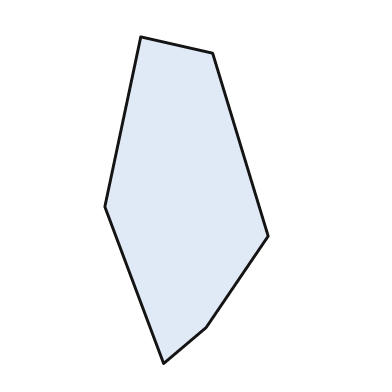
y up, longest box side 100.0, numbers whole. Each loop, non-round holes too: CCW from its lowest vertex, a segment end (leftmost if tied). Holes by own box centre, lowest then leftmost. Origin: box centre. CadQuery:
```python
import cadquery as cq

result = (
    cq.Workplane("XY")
    .moveTo(-7.0, -50.0)
    .lineTo(6.0, -39.0)
    .lineTo(25.0, -11.0)
    .lineTo(8.0, 45.0)
    .lineTo(-14.0, 50.0)
    .lineTo(-25.0, -2.0)
    .close()
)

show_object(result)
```